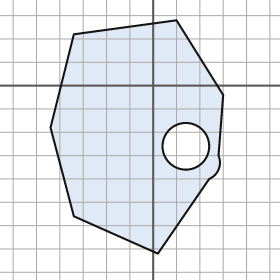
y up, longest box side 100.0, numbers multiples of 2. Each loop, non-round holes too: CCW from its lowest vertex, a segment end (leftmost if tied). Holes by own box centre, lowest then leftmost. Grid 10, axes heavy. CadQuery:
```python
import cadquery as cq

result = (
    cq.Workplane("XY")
    .moveTo(2.0, -72.0)
    .lineTo(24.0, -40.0)
    .threePointArc((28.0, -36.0), (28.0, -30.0))
    .lineTo(30.0, -4.0)
    .lineTo(10.0, 28.0)
    .lineTo(-34.0, 22.0)
    .lineTo(-44.0, -18.0)
    .lineTo(-34.0, -56.0)
    .close()
    .moveTo(14.0, -26.0)
    .circle(10.0)
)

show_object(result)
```